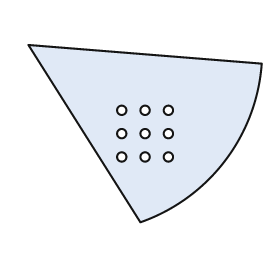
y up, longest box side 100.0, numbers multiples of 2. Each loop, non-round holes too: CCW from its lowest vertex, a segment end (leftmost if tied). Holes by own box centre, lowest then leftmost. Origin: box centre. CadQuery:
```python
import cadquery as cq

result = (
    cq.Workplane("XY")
    .moveTo(-2.0, -38.0)
    .threePointArc((34.0, -12.0), (50.0, 30.0))
    .lineTo(-50.0, 38.0)
    .close()
    .moveTo(-10.0, -10.0)
    .circle(2.0)
    .moveTo(0.0, -10.0)
    .circle(2.0)
    .moveTo(10.0, -10.0)
    .circle(2.0)
    .moveTo(-10.0, 0.0)
    .circle(2.0)
    .moveTo(0.0, 0.0)
    .circle(2.0)
    .moveTo(10.0, 0.0)
    .circle(2.0)
    .moveTo(-10.0, 10.0)
    .circle(2.0)
    .moveTo(0.0, 10.0)
    .circle(2.0)
    .moveTo(10.0, 10.0)
    .circle(2.0)
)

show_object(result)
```